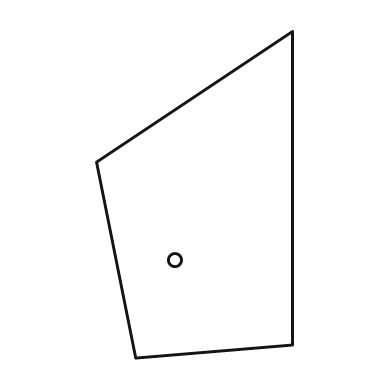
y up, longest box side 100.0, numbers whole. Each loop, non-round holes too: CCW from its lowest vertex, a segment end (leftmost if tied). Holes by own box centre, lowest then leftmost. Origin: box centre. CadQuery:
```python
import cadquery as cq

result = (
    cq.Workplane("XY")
    .moveTo(-18.0, -50.0)
    .lineTo(30.0, -46.0)
    .lineTo(30.0, 50.0)
    .lineTo(-30.0, 10.0)
    .close()
    .moveTo(-6.0, -20.0)
    .circle(2.0)
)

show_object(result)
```